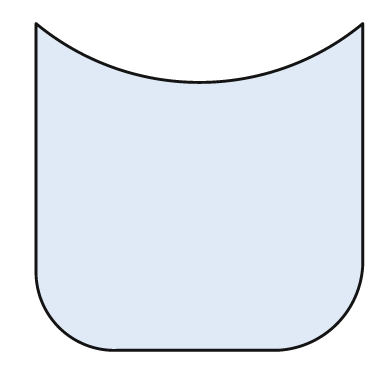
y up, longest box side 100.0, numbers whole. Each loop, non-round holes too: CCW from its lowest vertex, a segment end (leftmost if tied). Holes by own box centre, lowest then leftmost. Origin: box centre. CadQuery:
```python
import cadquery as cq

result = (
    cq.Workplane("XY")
    .moveTo(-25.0, -50.0)
    .lineTo(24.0, -50.0)
    .threePointArc((42.0, -42.0), (50.0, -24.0))
    .lineTo(50.0, 50.0)
    .threePointArc((0.0, 32.0), (-50.0, 50.0))
    .lineTo(-50.0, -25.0)
    .threePointArc((-43.0, -43.0), (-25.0, -50.0))
    .close()
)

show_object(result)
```